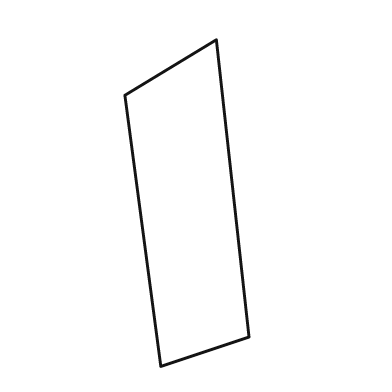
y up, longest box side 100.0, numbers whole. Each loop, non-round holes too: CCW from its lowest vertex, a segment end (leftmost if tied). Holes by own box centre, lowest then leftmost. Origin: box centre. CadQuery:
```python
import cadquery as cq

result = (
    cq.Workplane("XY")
    .moveTo(-8.0, -50.0)
    .lineTo(19.0, -41.0)
    .lineTo(9.0, 50.0)
    .lineTo(-19.0, 33.0)
    .close()
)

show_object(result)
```